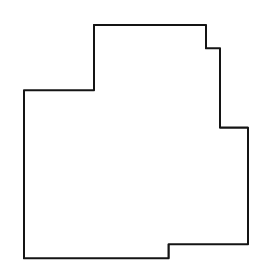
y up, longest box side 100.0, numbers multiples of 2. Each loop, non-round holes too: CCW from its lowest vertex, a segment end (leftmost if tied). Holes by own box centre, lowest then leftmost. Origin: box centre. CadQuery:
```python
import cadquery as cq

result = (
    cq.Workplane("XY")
    .moveTo(-48.0, -50.0)
    .lineTo(14.0, -50.0)
    .lineTo(14.0, -44.0)
    .lineTo(48.0, -44.0)
    .lineTo(48.0, 6.0)
    .lineTo(36.0, 6.0)
    .lineTo(36.0, 40.0)
    .lineTo(30.0, 40.0)
    .lineTo(30.0, 50.0)
    .lineTo(-18.0, 50.0)
    .lineTo(-18.0, 22.0)
    .lineTo(-48.0, 22.0)
    .close()
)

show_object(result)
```